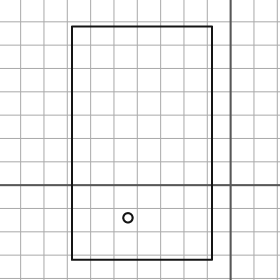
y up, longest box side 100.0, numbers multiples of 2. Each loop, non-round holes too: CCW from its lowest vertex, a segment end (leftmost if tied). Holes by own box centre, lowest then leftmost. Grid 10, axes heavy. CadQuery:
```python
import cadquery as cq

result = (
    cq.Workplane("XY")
    .moveTo(-68.0, -32.0)
    .lineTo(-8.0, -32.0)
    .lineTo(-8.0, 68.0)
    .lineTo(-68.0, 68.0)
    .close()
    .moveTo(-44.0, -14.0)
    .circle(2.0)
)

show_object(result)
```